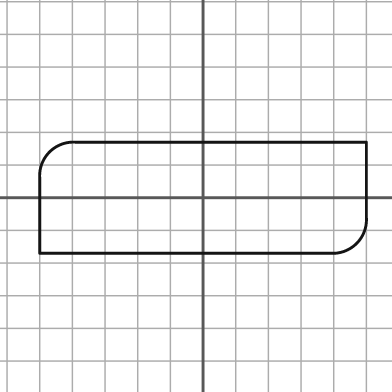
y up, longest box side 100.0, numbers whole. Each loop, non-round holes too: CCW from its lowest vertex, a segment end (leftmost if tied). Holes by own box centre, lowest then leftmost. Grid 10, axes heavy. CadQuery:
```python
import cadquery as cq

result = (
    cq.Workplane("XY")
    .moveTo(-50.0, -17.0)
    .lineTo(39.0, -17.0)
    .threePointArc((47.0, -14.0), (50.0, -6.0))
    .lineTo(50.0, 17.0)
    .lineTo(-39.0, 17.0)
    .threePointArc((-47.0, 14.0), (-50.0, 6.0))
    .close()
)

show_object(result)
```